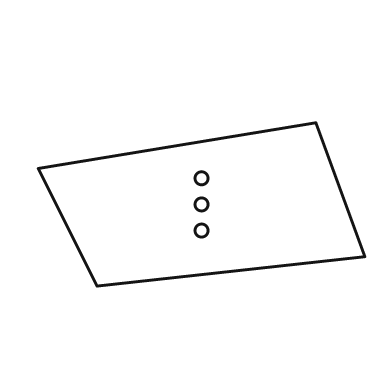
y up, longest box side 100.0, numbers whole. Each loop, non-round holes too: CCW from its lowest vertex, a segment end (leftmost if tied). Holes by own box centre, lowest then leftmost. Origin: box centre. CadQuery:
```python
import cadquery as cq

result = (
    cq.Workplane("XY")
    .moveTo(-32.0, -25.0)
    .lineTo(50.0, -16.0)
    .lineTo(35.0, 25.0)
    .lineTo(-50.0, 11.0)
    .close()
    .moveTo(0.0, -8.0)
    .circle(2.0)
    .moveTo(0.0, 0.0)
    .circle(2.0)
    .moveTo(0.0, 8.0)
    .circle(2.0)
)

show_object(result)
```